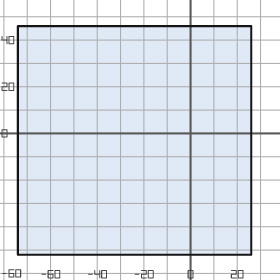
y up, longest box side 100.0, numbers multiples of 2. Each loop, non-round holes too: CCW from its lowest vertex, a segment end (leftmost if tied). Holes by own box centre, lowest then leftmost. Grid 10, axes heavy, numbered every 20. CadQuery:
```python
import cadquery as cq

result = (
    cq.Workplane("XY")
    .moveTo(-74.0, -52.0)
    .lineTo(26.0, -52.0)
    .lineTo(26.0, 46.0)
    .lineTo(-74.0, 46.0)
    .close()
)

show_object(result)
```